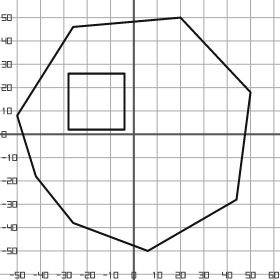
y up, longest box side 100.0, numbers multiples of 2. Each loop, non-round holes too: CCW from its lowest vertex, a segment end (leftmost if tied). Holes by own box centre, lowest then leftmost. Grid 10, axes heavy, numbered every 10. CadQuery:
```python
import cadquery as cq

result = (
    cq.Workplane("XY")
    .moveTo(6.0, -50.0)
    .lineTo(44.0, -28.0)
    .lineTo(50.0, 18.0)
    .lineTo(20.0, 50.0)
    .lineTo(-26.0, 46.0)
    .lineTo(-50.0, 8.0)
    .lineTo(-42.0, -18.0)
    .lineTo(-26.0, -38.0)
    .close()
    .moveTo(-28.0, 2.0)
    .lineTo(-4.0, 2.0)
    .lineTo(-4.0, 26.0)
    .lineTo(-28.0, 26.0)
    .close()
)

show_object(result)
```